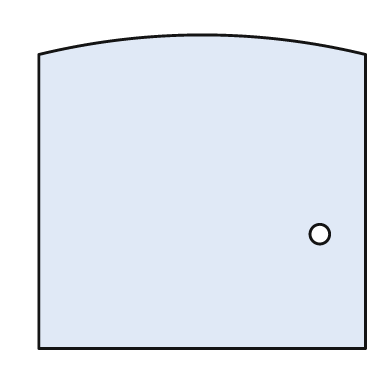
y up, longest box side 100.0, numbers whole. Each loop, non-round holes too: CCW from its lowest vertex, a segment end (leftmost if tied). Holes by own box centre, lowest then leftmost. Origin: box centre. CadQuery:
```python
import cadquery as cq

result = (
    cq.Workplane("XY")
    .moveTo(-50.0, -48.0)
    .lineTo(50.0, -48.0)
    .lineTo(50.0, 42.0)
    .threePointArc((0.0, 48.0), (-50.0, 42.0))
    .close()
    .moveTo(36.0, -13.0)
    .circle(3.0)
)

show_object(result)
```